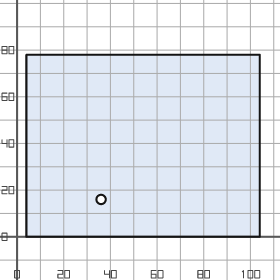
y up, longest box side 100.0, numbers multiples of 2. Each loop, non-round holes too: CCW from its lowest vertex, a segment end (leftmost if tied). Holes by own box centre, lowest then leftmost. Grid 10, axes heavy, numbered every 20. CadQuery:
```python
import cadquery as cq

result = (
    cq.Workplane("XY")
    .moveTo(4.0, 0.0)
    .lineTo(104.0, 0.0)
    .lineTo(104.0, 78.0)
    .lineTo(4.0, 78.0)
    .close()
    .moveTo(36.0, 16.0)
    .circle(2.0)
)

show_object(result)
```